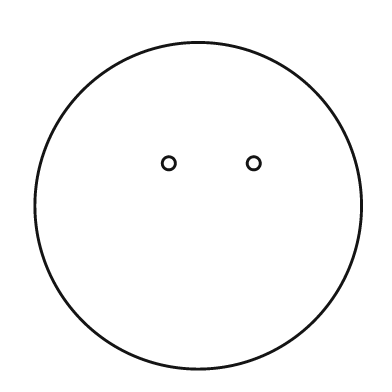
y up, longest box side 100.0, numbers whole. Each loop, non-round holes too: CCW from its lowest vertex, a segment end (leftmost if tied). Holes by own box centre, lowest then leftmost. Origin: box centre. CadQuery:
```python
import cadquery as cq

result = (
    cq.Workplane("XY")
    .moveTo(0.0, 0.0)
    .circle(50.0)
    .moveTo(-9.0, 13.0)
    .circle(2.0)
    .moveTo(17.0, 13.0)
    .circle(2.0)
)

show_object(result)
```